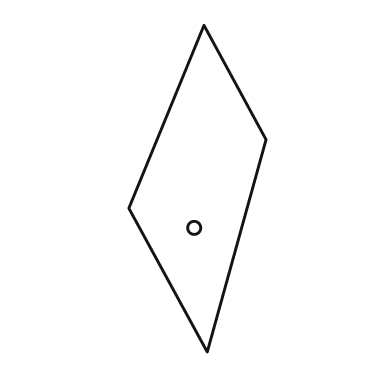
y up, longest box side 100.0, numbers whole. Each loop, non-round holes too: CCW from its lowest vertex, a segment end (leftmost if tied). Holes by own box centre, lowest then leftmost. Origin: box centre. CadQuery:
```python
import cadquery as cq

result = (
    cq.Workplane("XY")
    .moveTo(3.0, -50.0)
    .lineTo(21.0, 15.0)
    .lineTo(2.0, 50.0)
    .lineTo(-21.0, -6.0)
    .close()
    .moveTo(-1.0, -12.0)
    .circle(2.0)
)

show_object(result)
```